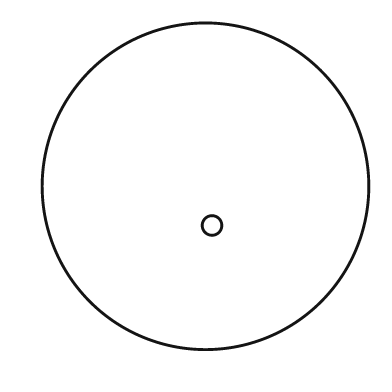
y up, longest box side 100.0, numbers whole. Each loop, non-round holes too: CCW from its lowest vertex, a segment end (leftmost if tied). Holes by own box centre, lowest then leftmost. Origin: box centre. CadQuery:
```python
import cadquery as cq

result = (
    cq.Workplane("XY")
    .moveTo(0.0, 0.0)
    .circle(50.0)
    .moveTo(2.0, -12.0)
    .circle(3.0)
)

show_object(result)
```